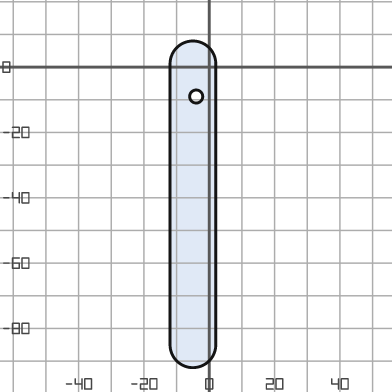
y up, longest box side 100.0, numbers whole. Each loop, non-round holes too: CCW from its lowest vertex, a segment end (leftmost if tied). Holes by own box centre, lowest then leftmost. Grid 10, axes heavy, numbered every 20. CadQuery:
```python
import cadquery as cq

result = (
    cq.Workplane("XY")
    .moveTo(-12.0, -85.0)
    .threePointArc((-5.0, -92.0), (2.0, -85.0))
    .lineTo(2.0, 1.0)
    .threePointArc((-5.0, 8.0), (-12.0, 1.0))
    .close()
    .moveTo(-4.0, -9.0)
    .circle(2.0)
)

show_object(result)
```